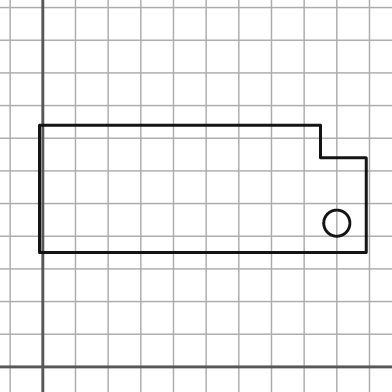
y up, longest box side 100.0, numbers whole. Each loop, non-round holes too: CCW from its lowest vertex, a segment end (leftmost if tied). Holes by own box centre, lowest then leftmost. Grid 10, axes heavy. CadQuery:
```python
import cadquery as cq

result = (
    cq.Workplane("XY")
    .moveTo(-1.0, 35.0)
    .lineTo(99.0, 35.0)
    .lineTo(99.0, 64.0)
    .lineTo(85.0, 64.0)
    .lineTo(85.0, 74.0)
    .lineTo(-1.0, 74.0)
    .close()
    .moveTo(90.0, 44.0)
    .circle(4.0)
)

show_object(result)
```